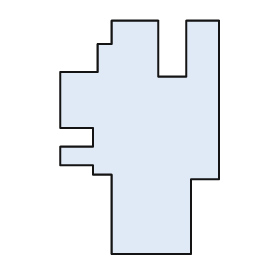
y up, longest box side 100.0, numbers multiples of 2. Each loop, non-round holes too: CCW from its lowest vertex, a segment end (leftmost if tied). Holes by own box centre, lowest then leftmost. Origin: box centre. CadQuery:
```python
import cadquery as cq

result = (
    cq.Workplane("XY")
    .moveTo(-12.0, -50.0)
    .lineTo(22.0, -50.0)
    .lineTo(22.0, -18.0)
    .lineTo(34.0, -18.0)
    .lineTo(34.0, 50.0)
    .lineTo(20.0, 50.0)
    .lineTo(20.0, 26.0)
    .lineTo(8.0, 26.0)
    .lineTo(8.0, 50.0)
    .lineTo(-12.0, 50.0)
    .lineTo(-12.0, 40.0)
    .lineTo(-18.0, 40.0)
    .lineTo(-18.0, 28.0)
    .lineTo(-34.0, 28.0)
    .lineTo(-34.0, 4.0)
    .lineTo(-20.0, 4.0)
    .lineTo(-20.0, -4.0)
    .lineTo(-34.0, -4.0)
    .lineTo(-34.0, -12.0)
    .lineTo(-20.0, -12.0)
    .lineTo(-20.0, -16.0)
    .lineTo(-12.0, -16.0)
    .close()
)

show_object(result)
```